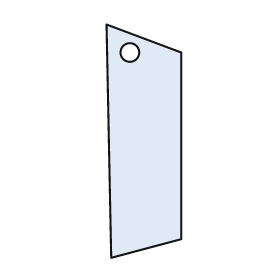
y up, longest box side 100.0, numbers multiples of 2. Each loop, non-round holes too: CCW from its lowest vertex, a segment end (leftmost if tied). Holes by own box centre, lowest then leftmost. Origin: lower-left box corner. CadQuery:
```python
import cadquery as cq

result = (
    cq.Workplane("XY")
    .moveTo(2.0, 0.0)
    .lineTo(32.0, 8.0)
    .lineTo(32.0, 88.0)
    .lineTo(0.0, 100.0)
    .close()
    .moveTo(10.0, 88.0)
    .circle(4.0)
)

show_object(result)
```